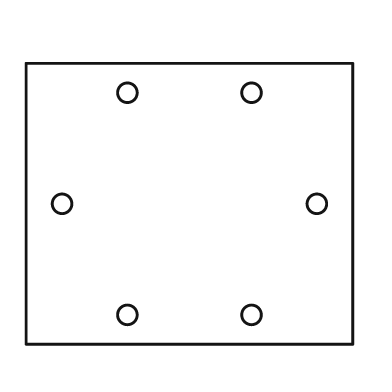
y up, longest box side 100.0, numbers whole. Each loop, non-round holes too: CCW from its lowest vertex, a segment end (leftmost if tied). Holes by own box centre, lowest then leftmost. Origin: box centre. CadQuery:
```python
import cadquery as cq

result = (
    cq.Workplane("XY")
    .moveTo(-50.0, -43.0)
    .lineTo(50.0, -43.0)
    .lineTo(50.0, 43.0)
    .lineTo(-50.0, 43.0)
    .close()
    .moveTo(-19.0, -34.0)
    .circle(3.0)
    .moveTo(19.0, -34.0)
    .circle(3.0)
    .moveTo(-39.0, 0.0)
    .circle(3.0)
    .moveTo(39.0, 0.0)
    .circle(3.0)
    .moveTo(-19.0, 34.0)
    .circle(3.0)
    .moveTo(19.0, 34.0)
    .circle(3.0)
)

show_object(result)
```